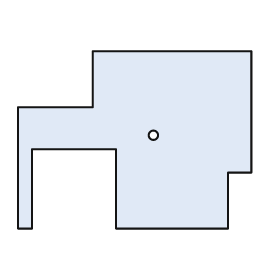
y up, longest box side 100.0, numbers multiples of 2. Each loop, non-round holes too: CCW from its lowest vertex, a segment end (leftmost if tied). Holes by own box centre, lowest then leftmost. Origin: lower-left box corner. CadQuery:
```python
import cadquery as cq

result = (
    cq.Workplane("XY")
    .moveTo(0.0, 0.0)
    .lineTo(6.0, 0.0)
    .lineTo(6.0, 34.0)
    .lineTo(42.0, 34.0)
    .lineTo(42.0, 0.0)
    .lineTo(90.0, 0.0)
    .lineTo(90.0, 24.0)
    .lineTo(100.0, 24.0)
    .lineTo(100.0, 76.0)
    .lineTo(32.0, 76.0)
    .lineTo(32.0, 52.0)
    .lineTo(0.0, 52.0)
    .close()
    .moveTo(58.0, 40.0)
    .circle(2.0)
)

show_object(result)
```